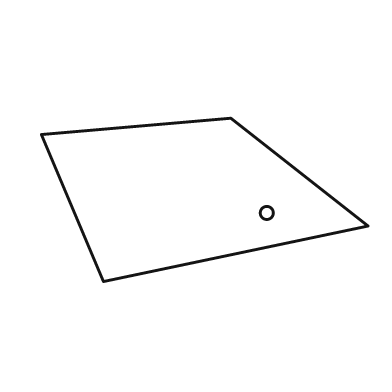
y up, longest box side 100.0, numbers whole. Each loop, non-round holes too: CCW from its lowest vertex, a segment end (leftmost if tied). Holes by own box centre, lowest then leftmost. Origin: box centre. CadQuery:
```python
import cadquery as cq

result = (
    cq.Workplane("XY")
    .moveTo(-31.0, -25.0)
    .lineTo(50.0, -8.0)
    .lineTo(8.0, 25.0)
    .lineTo(-50.0, 20.0)
    .close()
    .moveTo(19.0, -4.0)
    .circle(2.0)
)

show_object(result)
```